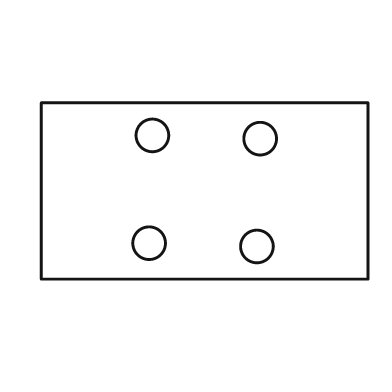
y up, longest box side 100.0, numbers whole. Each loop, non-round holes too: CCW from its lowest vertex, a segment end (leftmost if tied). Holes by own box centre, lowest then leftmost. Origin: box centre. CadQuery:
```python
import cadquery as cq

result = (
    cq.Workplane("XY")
    .moveTo(-50.0, -27.0)
    .lineTo(50.0, -27.0)
    .lineTo(50.0, 27.0)
    .lineTo(-50.0, 27.0)
    .close()
    .moveTo(16.0, -17.0)
    .circle(5.0)
    .moveTo(-17.0, -16.0)
    .circle(5.0)
    .moveTo(17.0, 16.0)
    .circle(5.0)
    .moveTo(-16.0, 17.0)
    .circle(5.0)
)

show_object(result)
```